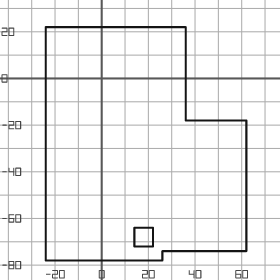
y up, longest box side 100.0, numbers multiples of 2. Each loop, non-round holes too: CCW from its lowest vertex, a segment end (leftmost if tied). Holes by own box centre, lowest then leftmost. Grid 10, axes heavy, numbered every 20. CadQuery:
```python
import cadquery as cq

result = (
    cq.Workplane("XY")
    .moveTo(-24.0, -78.0)
    .lineTo(26.0, -78.0)
    .lineTo(26.0, -74.0)
    .lineTo(62.0, -74.0)
    .lineTo(62.0, -18.0)
    .lineTo(36.0, -18.0)
    .lineTo(36.0, 22.0)
    .lineTo(-24.0, 22.0)
    .close()
    .moveTo(14.0, -72.0)
    .lineTo(22.0, -72.0)
    .lineTo(22.0, -64.0)
    .lineTo(14.0, -64.0)
    .close()
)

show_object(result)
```